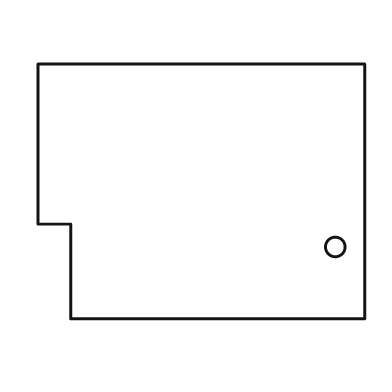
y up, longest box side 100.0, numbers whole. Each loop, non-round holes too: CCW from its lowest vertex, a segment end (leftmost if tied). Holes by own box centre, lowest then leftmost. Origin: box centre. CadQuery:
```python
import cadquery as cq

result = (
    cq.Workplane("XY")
    .moveTo(-40.0, -39.0)
    .lineTo(50.0, -39.0)
    .lineTo(50.0, 39.0)
    .lineTo(-50.0, 39.0)
    .lineTo(-50.0, -10.0)
    .lineTo(-40.0, -10.0)
    .close()
    .moveTo(41.0, -17.0)
    .circle(3.0)
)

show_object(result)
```